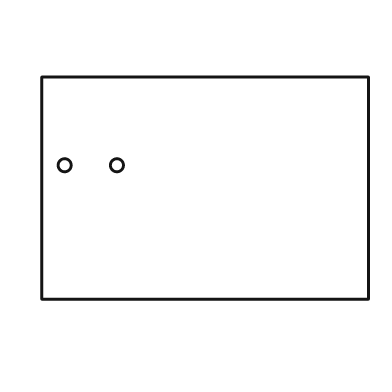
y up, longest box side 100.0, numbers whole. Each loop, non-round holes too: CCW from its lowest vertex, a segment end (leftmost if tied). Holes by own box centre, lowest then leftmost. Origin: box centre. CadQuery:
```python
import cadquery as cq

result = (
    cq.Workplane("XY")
    .moveTo(-50.0, -34.0)
    .lineTo(50.0, -34.0)
    .lineTo(50.0, 34.0)
    .lineTo(-50.0, 34.0)
    .close()
    .moveTo(-43.0, 7.0)
    .circle(2.0)
    .moveTo(-27.0, 7.0)
    .circle(2.0)
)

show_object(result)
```